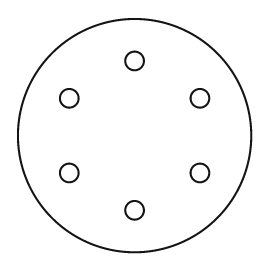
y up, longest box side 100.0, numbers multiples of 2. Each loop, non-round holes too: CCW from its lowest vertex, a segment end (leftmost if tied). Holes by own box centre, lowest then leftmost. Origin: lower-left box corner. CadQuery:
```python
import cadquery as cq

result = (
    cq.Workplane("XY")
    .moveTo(50.0, 50.0)
    .circle(50.0)
    .moveTo(50.0, 18.0)
    .circle(4.0)
    .moveTo(22.0, 34.0)
    .circle(4.0)
    .moveTo(78.0, 34.0)
    .circle(4.0)
    .moveTo(22.0, 66.0)
    .circle(4.0)
    .moveTo(78.0, 66.0)
    .circle(4.0)
    .moveTo(50.0, 82.0)
    .circle(4.0)
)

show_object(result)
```